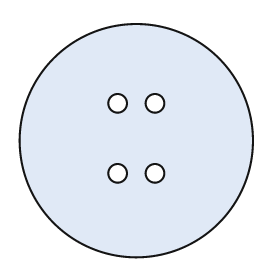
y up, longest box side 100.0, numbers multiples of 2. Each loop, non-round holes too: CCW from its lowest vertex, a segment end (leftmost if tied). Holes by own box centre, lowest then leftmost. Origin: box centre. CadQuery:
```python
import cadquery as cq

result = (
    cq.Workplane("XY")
    .moveTo(0.0, 0.0)
    .circle(50.0)
    .moveTo(-8.0, -14.0)
    .circle(4.0)
    .moveTo(8.0, -14.0)
    .circle(4.0)
    .moveTo(-8.0, 16.0)
    .circle(4.0)
    .moveTo(8.0, 16.0)
    .circle(4.0)
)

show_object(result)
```